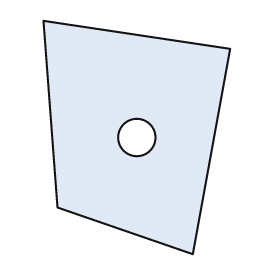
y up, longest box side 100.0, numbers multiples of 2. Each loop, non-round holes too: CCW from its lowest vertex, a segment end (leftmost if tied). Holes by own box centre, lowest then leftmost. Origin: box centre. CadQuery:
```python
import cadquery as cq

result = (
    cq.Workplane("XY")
    .moveTo(24.0, -50.0)
    .lineTo(40.0, 38.0)
    .lineTo(-40.0, 50.0)
    .lineTo(-34.0, -30.0)
    .close()
    .moveTo(0.0, 0.0)
    .circle(8.0)
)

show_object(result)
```